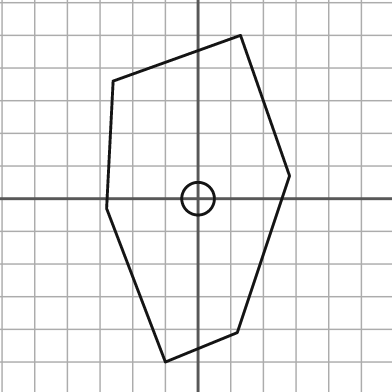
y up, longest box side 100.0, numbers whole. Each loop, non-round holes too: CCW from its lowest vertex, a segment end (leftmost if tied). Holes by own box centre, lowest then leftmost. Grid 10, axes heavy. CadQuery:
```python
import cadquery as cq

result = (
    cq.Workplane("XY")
    .moveTo(-10.0, -50.0)
    .lineTo(12.0, -41.0)
    .lineTo(28.0, 7.0)
    .lineTo(13.0, 50.0)
    .lineTo(-26.0, 36.0)
    .lineTo(-28.0, -3.0)
    .close()
    .moveTo(0.0, 0.0)
    .circle(5.0)
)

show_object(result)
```